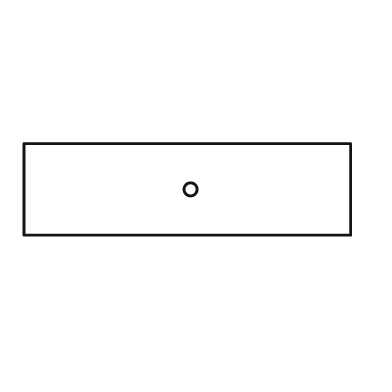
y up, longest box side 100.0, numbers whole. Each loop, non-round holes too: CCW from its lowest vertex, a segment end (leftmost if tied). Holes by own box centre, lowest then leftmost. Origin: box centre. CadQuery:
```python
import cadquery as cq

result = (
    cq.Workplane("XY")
    .moveTo(-50.0, -14.0)
    .lineTo(50.0, -14.0)
    .lineTo(50.0, 14.0)
    .lineTo(-50.0, 14.0)
    .close()
    .moveTo(1.0, 0.0)
    .circle(2.0)
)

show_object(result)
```